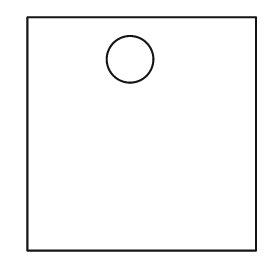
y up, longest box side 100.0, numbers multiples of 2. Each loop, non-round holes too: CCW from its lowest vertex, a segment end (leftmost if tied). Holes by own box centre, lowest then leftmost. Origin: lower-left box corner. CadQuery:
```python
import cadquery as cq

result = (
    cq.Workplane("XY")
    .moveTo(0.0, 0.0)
    .lineTo(98.0, 0.0)
    .lineTo(98.0, 100.0)
    .lineTo(0.0, 100.0)
    .close()
    .moveTo(44.0, 82.0)
    .circle(10.0)
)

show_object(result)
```